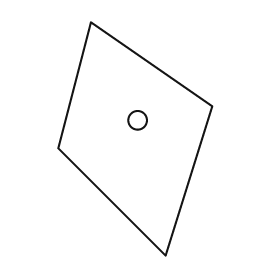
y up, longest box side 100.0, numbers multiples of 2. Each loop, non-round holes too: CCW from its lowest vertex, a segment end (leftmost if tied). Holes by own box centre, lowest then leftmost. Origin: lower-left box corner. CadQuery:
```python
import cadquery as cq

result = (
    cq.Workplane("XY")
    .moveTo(46.0, 0.0)
    .lineTo(66.0, 64.0)
    .lineTo(14.0, 100.0)
    .lineTo(0.0, 46.0)
    .close()
    .moveTo(34.0, 58.0)
    .circle(4.0)
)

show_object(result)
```